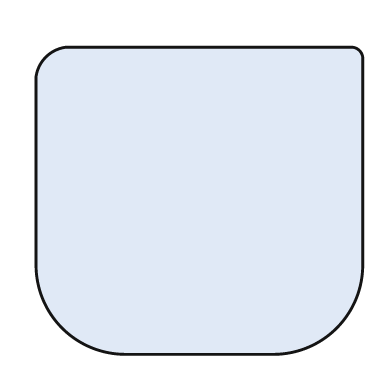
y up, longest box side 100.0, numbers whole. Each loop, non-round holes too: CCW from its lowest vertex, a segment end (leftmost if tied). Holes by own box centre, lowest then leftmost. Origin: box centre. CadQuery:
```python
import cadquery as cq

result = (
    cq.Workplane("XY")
    .moveTo(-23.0, -47.0)
    .lineTo(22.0, -47.0)
    .threePointArc((42.0, -39.0), (50.0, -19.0))
    .lineTo(50.0, 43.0)
    .threePointArc((49.0, 46.0), (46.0, 47.0))
    .lineTo(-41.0, 47.0)
    .threePointArc((-47.0, 44.0), (-50.0, 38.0))
    .lineTo(-50.0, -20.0)
    .threePointArc((-42.0, -39.0), (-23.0, -47.0))
    .close()
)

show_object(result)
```